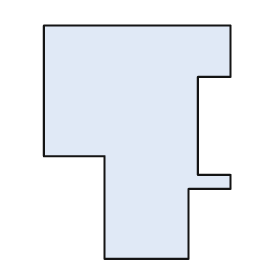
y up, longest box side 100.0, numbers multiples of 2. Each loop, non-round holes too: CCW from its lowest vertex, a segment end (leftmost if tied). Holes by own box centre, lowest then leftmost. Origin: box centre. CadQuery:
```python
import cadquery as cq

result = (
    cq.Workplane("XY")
    .moveTo(-14.0, -50.0)
    .lineTo(22.0, -50.0)
    .lineTo(22.0, -20.0)
    .lineTo(40.0, -20.0)
    .lineTo(40.0, -14.0)
    .lineTo(26.0, -14.0)
    .lineTo(26.0, 28.0)
    .lineTo(40.0, 28.0)
    .lineTo(40.0, 50.0)
    .lineTo(-40.0, 50.0)
    .lineTo(-40.0, -6.0)
    .lineTo(-14.0, -6.0)
    .close()
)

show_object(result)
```